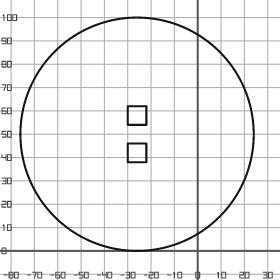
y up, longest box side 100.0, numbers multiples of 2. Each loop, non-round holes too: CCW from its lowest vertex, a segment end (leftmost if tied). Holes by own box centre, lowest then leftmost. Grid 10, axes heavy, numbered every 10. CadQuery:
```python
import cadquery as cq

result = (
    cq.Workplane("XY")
    .moveTo(-26.0, 50.0)
    .circle(50.0)
    .moveTo(-30.0, 38.0)
    .lineTo(-22.0, 38.0)
    .lineTo(-22.0, 46.0)
    .lineTo(-30.0, 46.0)
    .close()
    .moveTo(-30.0, 54.0)
    .lineTo(-22.0, 54.0)
    .lineTo(-22.0, 62.0)
    .lineTo(-30.0, 62.0)
    .close()
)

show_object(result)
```